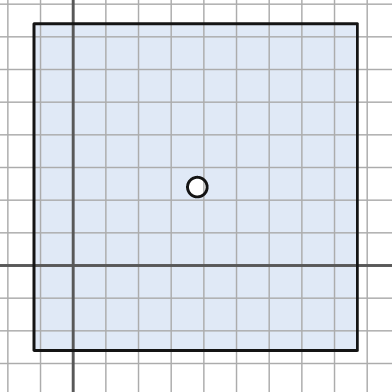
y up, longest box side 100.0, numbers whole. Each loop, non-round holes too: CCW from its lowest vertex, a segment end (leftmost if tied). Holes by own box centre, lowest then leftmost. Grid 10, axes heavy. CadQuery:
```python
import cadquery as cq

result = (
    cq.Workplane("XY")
    .moveTo(-12.0, -26.0)
    .lineTo(87.0, -26.0)
    .lineTo(87.0, 74.0)
    .lineTo(-12.0, 74.0)
    .close()
    .moveTo(38.0, 24.0)
    .circle(3.0)
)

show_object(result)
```